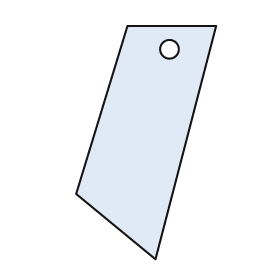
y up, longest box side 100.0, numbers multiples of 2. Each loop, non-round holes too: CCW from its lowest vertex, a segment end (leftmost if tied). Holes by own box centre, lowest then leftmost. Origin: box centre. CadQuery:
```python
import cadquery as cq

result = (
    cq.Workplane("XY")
    .moveTo(4.0, -50.0)
    .lineTo(30.0, 50.0)
    .lineTo(-8.0, 50.0)
    .lineTo(-30.0, -22.0)
    .close()
    .moveTo(10.0, 40.0)
    .circle(4.0)
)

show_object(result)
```